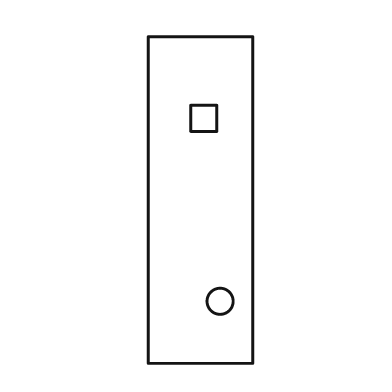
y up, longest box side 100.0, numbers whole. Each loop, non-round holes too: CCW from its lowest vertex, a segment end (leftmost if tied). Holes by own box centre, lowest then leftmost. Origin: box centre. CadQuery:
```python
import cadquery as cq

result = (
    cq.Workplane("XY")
    .moveTo(-16.0, -50.0)
    .lineTo(16.0, -50.0)
    .lineTo(16.0, 50.0)
    .lineTo(-16.0, 50.0)
    .close()
    .moveTo(6.0, -31.0)
    .circle(4.0)
    .moveTo(-3.0, 21.0)
    .lineTo(5.0, 21.0)
    .lineTo(5.0, 29.0)
    .lineTo(-3.0, 29.0)
    .close()
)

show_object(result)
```